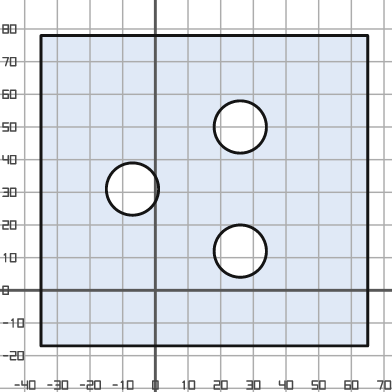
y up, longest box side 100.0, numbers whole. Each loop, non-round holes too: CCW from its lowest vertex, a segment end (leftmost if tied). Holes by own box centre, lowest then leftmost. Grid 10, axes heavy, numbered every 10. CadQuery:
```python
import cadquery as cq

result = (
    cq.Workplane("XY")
    .moveTo(-35.0, -17.0)
    .lineTo(65.0, -17.0)
    .lineTo(65.0, 78.0)
    .lineTo(-35.0, 78.0)
    .close()
    .moveTo(26.0, 12.0)
    .circle(8.0)
    .moveTo(-7.0, 31.0)
    .circle(8.0)
    .moveTo(26.0, 50.0)
    .circle(8.0)
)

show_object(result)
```